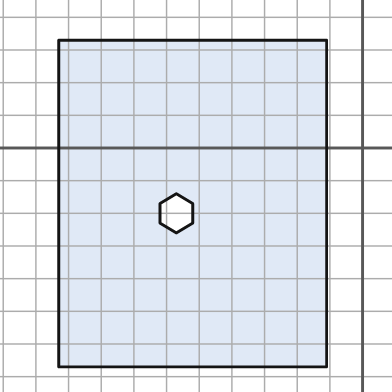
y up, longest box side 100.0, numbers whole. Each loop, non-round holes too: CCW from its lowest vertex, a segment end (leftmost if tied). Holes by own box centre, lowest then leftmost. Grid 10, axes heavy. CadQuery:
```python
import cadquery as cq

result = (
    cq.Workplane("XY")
    .moveTo(-93.0, -67.0)
    .lineTo(-11.0, -67.0)
    .lineTo(-11.0, 33.0)
    .lineTo(-93.0, 33.0)
    .close()
    .moveTo(-57.0, -26.0)
    .lineTo(-52.0, -23.0)
    .lineTo(-52.0, -17.0)
    .lineTo(-57.0, -14.0)
    .lineTo(-62.0, -17.0)
    .lineTo(-62.0, -23.0)
    .close()
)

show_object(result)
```